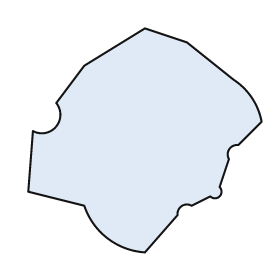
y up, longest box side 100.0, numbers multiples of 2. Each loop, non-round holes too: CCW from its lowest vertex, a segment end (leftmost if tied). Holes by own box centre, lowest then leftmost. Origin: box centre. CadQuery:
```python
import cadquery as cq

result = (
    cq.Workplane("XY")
    .moveTo(0.0, -48.0)
    .lineTo(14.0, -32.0)
    .threePointArc((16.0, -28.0), (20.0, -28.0))
    .lineTo(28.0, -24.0)
    .threePointArc((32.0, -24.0), (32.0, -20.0))
    .lineTo(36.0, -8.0)
    .threePointArc((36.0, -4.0), (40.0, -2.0))
    .lineTo(50.0, 8.0)
    .threePointArc((46.0, 18.0), (38.0, 26.0))
    .lineTo(18.0, 42.0)
    .lineTo(0.0, 48.0)
    .lineTo(-26.0, 32.0)
    .lineTo(-38.0, 16.0)
    .threePointArc((-38.0, 6.0), (-48.0, 4.0))
    .lineTo(-50.0, -22.0)
    .lineTo(-26.0, -28.0)
    .threePointArc((-16.0, -42.0), (0.0, -48.0))
    .close()
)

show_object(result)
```